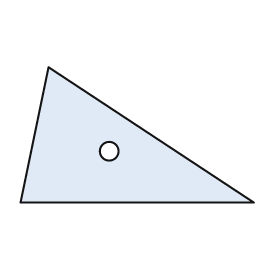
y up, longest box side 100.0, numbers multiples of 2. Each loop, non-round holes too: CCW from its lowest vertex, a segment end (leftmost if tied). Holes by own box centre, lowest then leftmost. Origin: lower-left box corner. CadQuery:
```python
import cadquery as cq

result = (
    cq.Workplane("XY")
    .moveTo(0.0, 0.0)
    .lineTo(100.0, 0.0)
    .lineTo(12.0, 58.0)
    .close()
    .moveTo(38.0, 22.0)
    .circle(4.0)
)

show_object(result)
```